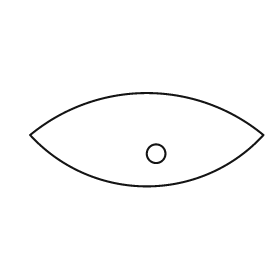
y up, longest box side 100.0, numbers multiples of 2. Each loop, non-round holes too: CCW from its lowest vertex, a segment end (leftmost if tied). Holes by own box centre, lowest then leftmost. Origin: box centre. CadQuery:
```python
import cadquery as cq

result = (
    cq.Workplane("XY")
    .moveTo(-50.0, 2.0)
    .threePointArc((0.0, -20.0), (50.0, 2.0))
    .threePointArc((0.0, 20.0), (-50.0, 2.0))
    .close()
    .moveTo(4.0, -6.0)
    .circle(4.0)
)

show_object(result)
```